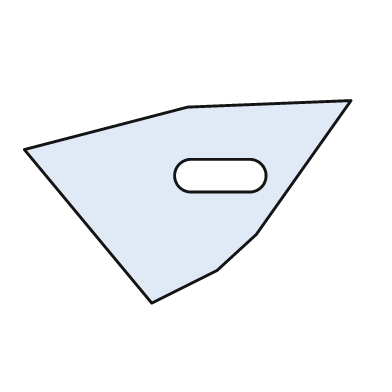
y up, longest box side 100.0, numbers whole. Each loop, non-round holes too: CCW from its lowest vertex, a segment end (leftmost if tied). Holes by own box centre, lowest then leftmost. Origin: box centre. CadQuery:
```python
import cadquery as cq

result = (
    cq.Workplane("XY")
    .moveTo(-11.0, -31.0)
    .lineTo(9.0, -21.0)
    .lineTo(21.0, -10.0)
    .lineTo(50.0, 31.0)
    .lineTo(0.0, 29.0)
    .lineTo(-50.0, 16.0)
    .close()
    .moveTo(1.0, 3.0)
    .lineTo(19.0, 3.0)
    .threePointArc((24.0, 8.0), (19.0, 13.0))
    .lineTo(1.0, 13.0)
    .threePointArc((-4.0, 8.0), (1.0, 3.0))
    .close()
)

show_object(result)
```